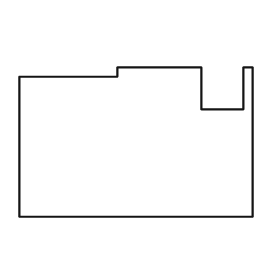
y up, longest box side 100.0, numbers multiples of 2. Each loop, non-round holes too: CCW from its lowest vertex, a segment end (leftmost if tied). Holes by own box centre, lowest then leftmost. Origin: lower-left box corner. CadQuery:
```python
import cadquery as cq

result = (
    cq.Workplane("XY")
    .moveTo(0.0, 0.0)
    .lineTo(100.0, 0.0)
    .lineTo(100.0, 64.0)
    .lineTo(96.0, 64.0)
    .lineTo(96.0, 46.0)
    .lineTo(78.0, 46.0)
    .lineTo(78.0, 64.0)
    .lineTo(42.0, 64.0)
    .lineTo(42.0, 60.0)
    .lineTo(0.0, 60.0)
    .close()
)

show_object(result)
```